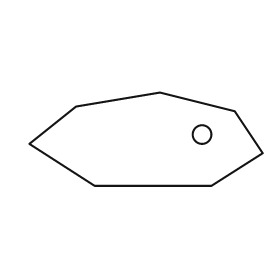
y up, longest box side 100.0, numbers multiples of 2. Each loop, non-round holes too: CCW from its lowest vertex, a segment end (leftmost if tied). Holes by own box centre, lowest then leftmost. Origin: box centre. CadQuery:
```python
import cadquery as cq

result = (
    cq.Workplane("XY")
    .moveTo(-22.0, -20.0)
    .lineTo(28.0, -20.0)
    .lineTo(50.0, -6.0)
    .lineTo(38.0, 12.0)
    .lineTo(6.0, 20.0)
    .lineTo(-30.0, 14.0)
    .lineTo(-50.0, -2.0)
    .close()
    .moveTo(24.0, 2.0)
    .circle(4.0)
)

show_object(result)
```